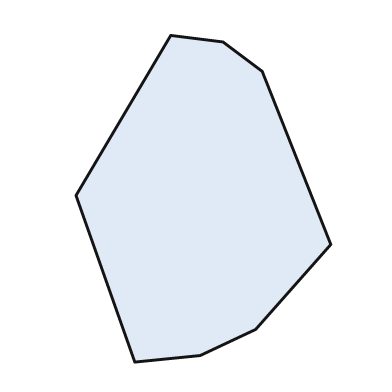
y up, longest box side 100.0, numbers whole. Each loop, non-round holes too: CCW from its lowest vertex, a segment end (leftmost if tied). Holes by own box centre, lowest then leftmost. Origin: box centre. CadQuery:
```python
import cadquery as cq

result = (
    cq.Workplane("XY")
    .moveTo(-21.0, -50.0)
    .lineTo(-1.0, -48.0)
    .lineTo(16.0, -40.0)
    .lineTo(39.0, -14.0)
    .lineTo(18.0, 39.0)
    .lineTo(6.0, 48.0)
    .lineTo(-10.0, 50.0)
    .lineTo(-39.0, 1.0)
    .close()
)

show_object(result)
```